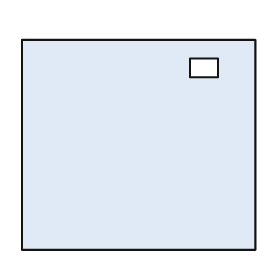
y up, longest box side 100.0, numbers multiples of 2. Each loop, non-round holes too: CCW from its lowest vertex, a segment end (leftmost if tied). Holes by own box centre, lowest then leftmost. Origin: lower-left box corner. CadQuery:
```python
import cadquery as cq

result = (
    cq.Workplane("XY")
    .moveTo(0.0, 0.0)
    .lineTo(100.0, 0.0)
    .lineTo(100.0, 90.0)
    .lineTo(0.0, 90.0)
    .close()
    .moveTo(72.0, 74.0)
    .lineTo(84.0, 74.0)
    .lineTo(84.0, 82.0)
    .lineTo(72.0, 82.0)
    .close()
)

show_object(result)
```